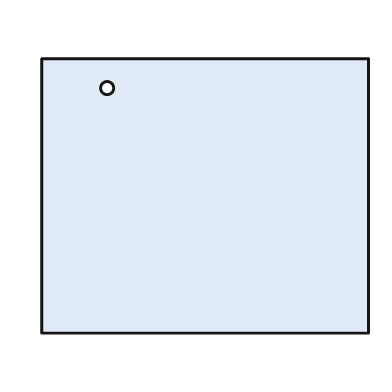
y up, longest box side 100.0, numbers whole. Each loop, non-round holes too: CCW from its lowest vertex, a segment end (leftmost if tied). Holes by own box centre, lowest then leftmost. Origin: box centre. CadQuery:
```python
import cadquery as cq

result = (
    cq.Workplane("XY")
    .moveTo(-50.0, -42.0)
    .lineTo(50.0, -42.0)
    .lineTo(50.0, 42.0)
    .lineTo(-50.0, 42.0)
    .close()
    .moveTo(-30.0, 33.0)
    .circle(2.0)
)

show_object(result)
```